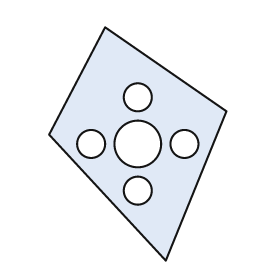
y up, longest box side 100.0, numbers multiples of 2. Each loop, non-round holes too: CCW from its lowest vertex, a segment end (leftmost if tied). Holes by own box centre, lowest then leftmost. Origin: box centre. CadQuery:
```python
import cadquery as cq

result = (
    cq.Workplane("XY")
    .moveTo(12.0, -50.0)
    .lineTo(38.0, 14.0)
    .lineTo(-14.0, 50.0)
    .lineTo(-38.0, 4.0)
    .close()
    .moveTo(0.0, -20.0)
    .circle(6.0)
    .moveTo(-20.0, 0.0)
    .circle(6.0)
    .moveTo(0.0, 0.0)
    .circle(10.0)
    .moveTo(20.0, 0.0)
    .circle(6.0)
    .moveTo(0.0, 20.0)
    .circle(6.0)
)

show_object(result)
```